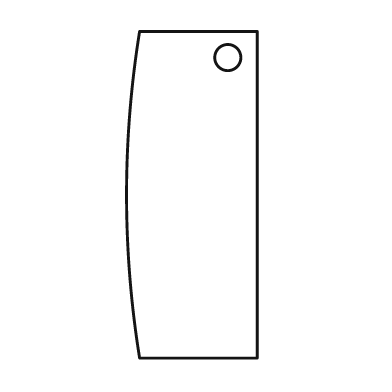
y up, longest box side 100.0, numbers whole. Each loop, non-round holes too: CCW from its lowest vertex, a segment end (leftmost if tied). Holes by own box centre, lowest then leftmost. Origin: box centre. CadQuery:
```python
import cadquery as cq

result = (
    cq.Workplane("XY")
    .moveTo(-16.0, -50.0)
    .lineTo(20.0, -50.0)
    .lineTo(20.0, 50.0)
    .lineTo(-16.0, 50.0)
    .threePointArc((-20.0, 0.0), (-16.0, -50.0))
    .close()
    .moveTo(11.0, 42.0)
    .circle(4.0)
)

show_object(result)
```